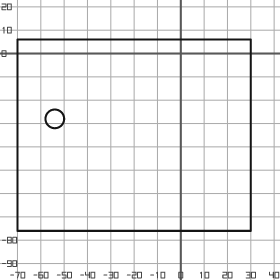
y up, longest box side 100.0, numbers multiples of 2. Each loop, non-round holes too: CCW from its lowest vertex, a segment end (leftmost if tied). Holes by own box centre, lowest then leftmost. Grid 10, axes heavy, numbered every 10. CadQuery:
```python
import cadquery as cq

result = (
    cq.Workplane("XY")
    .moveTo(-70.0, -76.0)
    .lineTo(30.0, -76.0)
    .lineTo(30.0, 6.0)
    .lineTo(-70.0, 6.0)
    .close()
    .moveTo(-54.0, -28.0)
    .circle(4.0)
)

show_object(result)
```